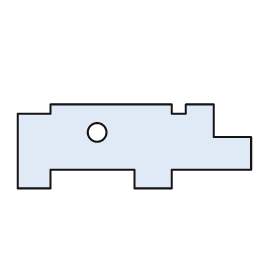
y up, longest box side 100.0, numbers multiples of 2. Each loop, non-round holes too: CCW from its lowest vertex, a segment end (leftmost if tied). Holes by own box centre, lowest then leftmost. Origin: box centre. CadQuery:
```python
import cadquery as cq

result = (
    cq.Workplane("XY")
    .moveTo(-50.0, -18.0)
    .lineTo(-36.0, -18.0)
    .lineTo(-36.0, -10.0)
    .lineTo(0.0, -10.0)
    .lineTo(0.0, -18.0)
    .lineTo(16.0, -18.0)
    .lineTo(16.0, -10.0)
    .lineTo(50.0, -10.0)
    .lineTo(50.0, 4.0)
    .lineTo(34.0, 4.0)
    .lineTo(34.0, 18.0)
    .lineTo(22.0, 18.0)
    .lineTo(22.0, 14.0)
    .lineTo(16.0, 14.0)
    .lineTo(16.0, 18.0)
    .lineTo(-36.0, 18.0)
    .lineTo(-36.0, 14.0)
    .lineTo(-50.0, 14.0)
    .close()
    .moveTo(-16.0, 6.0)
    .circle(4.0)
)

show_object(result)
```